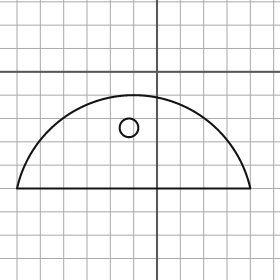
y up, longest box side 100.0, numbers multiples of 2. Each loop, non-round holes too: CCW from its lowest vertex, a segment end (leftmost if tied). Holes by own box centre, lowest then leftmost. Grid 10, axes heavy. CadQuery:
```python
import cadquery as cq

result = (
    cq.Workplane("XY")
    .moveTo(-60.0, -50.0)
    .lineTo(40.0, -50.0)
    .threePointArc((-10.0, -10.0), (-60.0, -50.0))
    .close()
    .moveTo(-12.0, -24.0)
    .circle(4.0)
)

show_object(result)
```